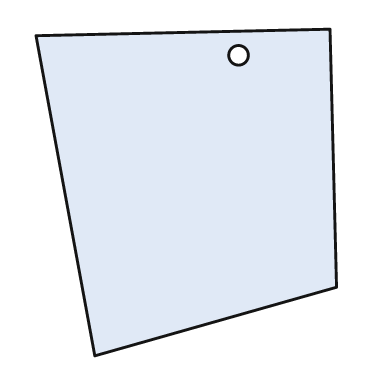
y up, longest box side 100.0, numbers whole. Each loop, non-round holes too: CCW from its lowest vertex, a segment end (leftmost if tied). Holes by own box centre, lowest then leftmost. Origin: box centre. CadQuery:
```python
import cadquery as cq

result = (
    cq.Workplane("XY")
    .moveTo(-28.0, -50.0)
    .lineTo(46.0, -29.0)
    .lineTo(44.0, 50.0)
    .lineTo(-46.0, 48.0)
    .close()
    .moveTo(16.0, 42.0)
    .circle(3.0)
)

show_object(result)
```